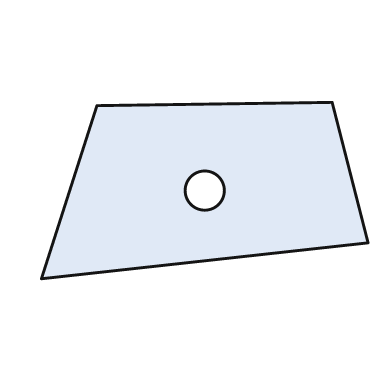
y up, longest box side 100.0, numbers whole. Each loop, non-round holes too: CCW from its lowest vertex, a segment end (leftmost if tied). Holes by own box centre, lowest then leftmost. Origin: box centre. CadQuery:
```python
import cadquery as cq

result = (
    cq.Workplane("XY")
    .moveTo(-50.0, -27.0)
    .lineTo(50.0, -16.0)
    .lineTo(39.0, 27.0)
    .lineTo(-33.0, 26.0)
    .close()
    .moveTo(0.0, 0.0)
    .circle(6.0)
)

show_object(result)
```